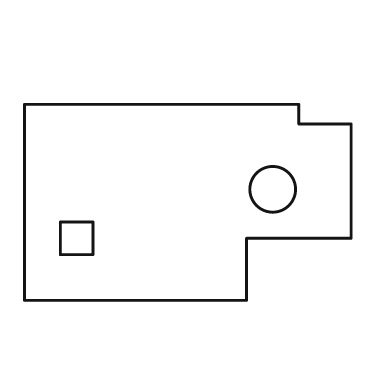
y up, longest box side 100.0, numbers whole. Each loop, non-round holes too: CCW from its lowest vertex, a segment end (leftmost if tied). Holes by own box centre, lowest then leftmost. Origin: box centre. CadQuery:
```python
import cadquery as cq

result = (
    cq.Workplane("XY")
    .moveTo(-50.0, -30.0)
    .lineTo(18.0, -30.0)
    .lineTo(18.0, -11.0)
    .lineTo(50.0, -11.0)
    .lineTo(50.0, 24.0)
    .lineTo(34.0, 24.0)
    .lineTo(34.0, 30.0)
    .lineTo(-50.0, 30.0)
    .close()
    .moveTo(-39.0, -16.0)
    .lineTo(-29.0, -16.0)
    .lineTo(-29.0, -6.0)
    .lineTo(-39.0, -6.0)
    .close()
    .moveTo(26.0, 4.0)
    .circle(7.0)
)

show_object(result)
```